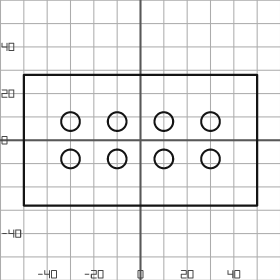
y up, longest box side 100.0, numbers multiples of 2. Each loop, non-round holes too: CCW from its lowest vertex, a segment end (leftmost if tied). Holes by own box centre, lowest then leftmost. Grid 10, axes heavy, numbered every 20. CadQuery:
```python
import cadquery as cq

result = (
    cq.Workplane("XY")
    .moveTo(-50.0, -28.0)
    .lineTo(50.0, -28.0)
    .lineTo(50.0, 28.0)
    .lineTo(-50.0, 28.0)
    .close()
    .moveTo(-30.0, -8.0)
    .circle(4.0)
    .moveTo(-10.0, -8.0)
    .circle(4.0)
    .moveTo(10.0, -8.0)
    .circle(4.0)
    .moveTo(30.0, -8.0)
    .circle(4.0)
    .moveTo(-30.0, 8.0)
    .circle(4.0)
    .moveTo(-10.0, 8.0)
    .circle(4.0)
    .moveTo(10.0, 8.0)
    .circle(4.0)
    .moveTo(30.0, 8.0)
    .circle(4.0)
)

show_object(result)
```